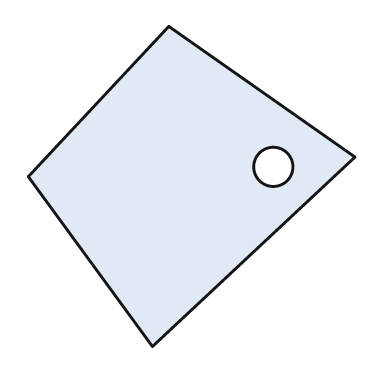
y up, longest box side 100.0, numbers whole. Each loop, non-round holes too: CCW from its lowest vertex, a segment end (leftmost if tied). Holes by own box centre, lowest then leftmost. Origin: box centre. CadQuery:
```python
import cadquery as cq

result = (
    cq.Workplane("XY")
    .moveTo(-12.0, -49.0)
    .lineTo(50.0, 9.0)
    .lineTo(-7.0, 49.0)
    .lineTo(-50.0, 3.0)
    .close()
    .moveTo(25.0, 6.0)
    .circle(6.0)
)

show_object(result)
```